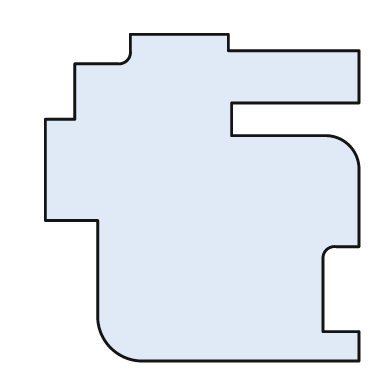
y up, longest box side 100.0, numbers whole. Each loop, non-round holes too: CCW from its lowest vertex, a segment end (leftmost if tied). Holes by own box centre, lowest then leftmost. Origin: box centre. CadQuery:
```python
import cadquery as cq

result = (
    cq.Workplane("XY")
    .moveTo(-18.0, -50.0)
    .lineTo(48.0, -50.0)
    .lineTo(48.0, -41.0)
    .lineTo(37.0, -41.0)
    .lineTo(37.0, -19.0)
    .threePointArc((38.0, -16.0), (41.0, -15.0))
    .lineTo(48.0, -15.0)
    .lineTo(48.0, 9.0)
    .threePointArc((45.0, 16.0), (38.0, 19.0))
    .lineTo(9.0, 19.0)
    .lineTo(9.0, 29.0)
    .lineTo(48.0, 29.0)
    .lineTo(48.0, 45.0)
    .lineTo(8.0, 45.0)
    .lineTo(8.0, 50.0)
    .lineTo(-22.0, 50.0)
    .lineTo(-22.0, 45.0)
    .threePointArc((-23.0, 42.0), (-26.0, 41.0))
    .lineTo(-39.0, 41.0)
    .lineTo(-39.0, 24.0)
    .lineTo(-48.0, 24.0)
    .lineTo(-48.0, -7.0)
    .lineTo(-32.0, -7.0)
    .lineTo(-32.0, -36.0)
    .threePointArc((-28.0, -46.0), (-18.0, -50.0))
    .close()
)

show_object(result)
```